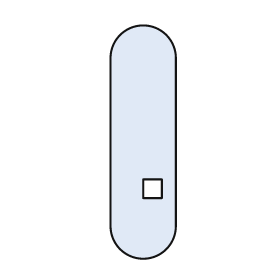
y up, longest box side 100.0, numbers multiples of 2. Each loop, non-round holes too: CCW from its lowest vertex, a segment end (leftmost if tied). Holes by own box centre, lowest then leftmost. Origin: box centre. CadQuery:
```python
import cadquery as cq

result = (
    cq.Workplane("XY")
    .moveTo(-14.0, -36.0)
    .threePointArc((0.0, -50.0), (14.0, -36.0))
    .lineTo(14.0, 36.0)
    .threePointArc((0.0, 50.0), (-14.0, 36.0))
    .close()
    .moveTo(0.0, -24.0)
    .lineTo(8.0, -24.0)
    .lineTo(8.0, -16.0)
    .lineTo(0.0, -16.0)
    .close()
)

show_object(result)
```